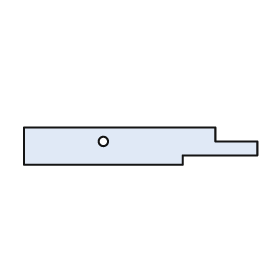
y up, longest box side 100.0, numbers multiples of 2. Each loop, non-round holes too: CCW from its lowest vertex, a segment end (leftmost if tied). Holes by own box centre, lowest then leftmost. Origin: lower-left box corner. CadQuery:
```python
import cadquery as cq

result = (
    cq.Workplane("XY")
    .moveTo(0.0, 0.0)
    .lineTo(68.0, 0.0)
    .lineTo(68.0, 4.0)
    .lineTo(100.0, 4.0)
    .lineTo(100.0, 10.0)
    .lineTo(82.0, 10.0)
    .lineTo(82.0, 16.0)
    .lineTo(0.0, 16.0)
    .close()
    .moveTo(34.0, 10.0)
    .circle(2.0)
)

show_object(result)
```